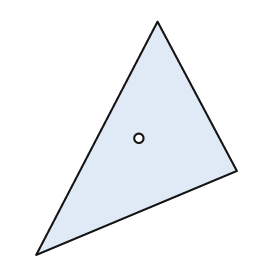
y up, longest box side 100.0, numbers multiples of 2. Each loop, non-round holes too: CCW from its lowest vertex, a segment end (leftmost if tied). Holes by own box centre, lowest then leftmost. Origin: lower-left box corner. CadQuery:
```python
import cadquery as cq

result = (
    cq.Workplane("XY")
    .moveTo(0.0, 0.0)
    .lineTo(86.0, 36.0)
    .lineTo(52.0, 100.0)
    .close()
    .moveTo(44.0, 50.0)
    .circle(2.0)
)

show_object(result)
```